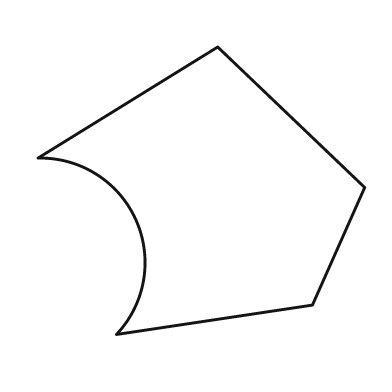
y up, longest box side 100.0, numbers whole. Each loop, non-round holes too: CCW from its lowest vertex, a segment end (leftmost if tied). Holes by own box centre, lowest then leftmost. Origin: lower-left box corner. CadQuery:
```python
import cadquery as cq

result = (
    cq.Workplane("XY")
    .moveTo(24.0, 0.0)
    .lineTo(84.0, 9.0)
    .lineTo(100.0, 45.0)
    .lineTo(55.0, 88.0)
    .lineTo(0.0, 54.0)
    .threePointArc((30.0, 35.0), (24.0, 0.0))
    .close()
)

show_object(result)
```